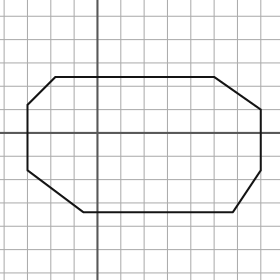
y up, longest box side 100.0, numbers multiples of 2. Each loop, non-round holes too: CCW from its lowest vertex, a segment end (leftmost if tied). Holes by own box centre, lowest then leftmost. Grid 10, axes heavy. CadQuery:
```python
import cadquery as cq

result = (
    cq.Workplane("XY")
    .moveTo(-6.0, -34.0)
    .lineTo(58.0, -34.0)
    .lineTo(70.0, -16.0)
    .lineTo(70.0, 10.0)
    .lineTo(50.0, 24.0)
    .lineTo(-18.0, 24.0)
    .lineTo(-30.0, 12.0)
    .lineTo(-30.0, -16.0)
    .close()
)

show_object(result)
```